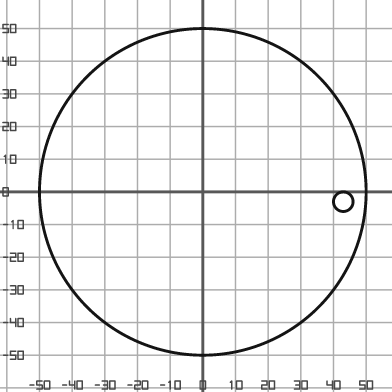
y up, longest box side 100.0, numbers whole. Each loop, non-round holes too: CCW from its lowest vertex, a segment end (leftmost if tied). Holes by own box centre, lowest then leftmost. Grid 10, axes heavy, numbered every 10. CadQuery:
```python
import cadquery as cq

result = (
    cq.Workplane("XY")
    .moveTo(0.0, 0.0)
    .circle(50.0)
    .moveTo(43.0, -3.0)
    .circle(3.0)
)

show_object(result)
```